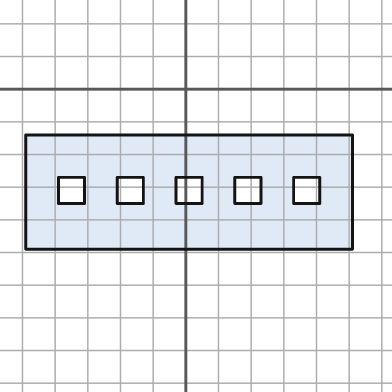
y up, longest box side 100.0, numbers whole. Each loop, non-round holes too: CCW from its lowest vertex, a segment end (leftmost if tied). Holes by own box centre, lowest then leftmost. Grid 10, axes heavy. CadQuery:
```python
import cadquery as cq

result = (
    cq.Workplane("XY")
    .moveTo(-49.0, -49.0)
    .lineTo(51.0, -49.0)
    .lineTo(51.0, -14.0)
    .lineTo(-49.0, -14.0)
    .close()
    .moveTo(-39.0, -35.0)
    .lineTo(-31.0, -35.0)
    .lineTo(-31.0, -27.0)
    .lineTo(-39.0, -27.0)
    .close()
    .moveTo(-21.0, -35.0)
    .lineTo(-13.0, -35.0)
    .lineTo(-13.0, -27.0)
    .lineTo(-21.0, -27.0)
    .close()
    .moveTo(-3.0, -35.0)
    .lineTo(5.0, -35.0)
    .lineTo(5.0, -27.0)
    .lineTo(-3.0, -27.0)
    .close()
    .moveTo(15.0, -35.0)
    .lineTo(23.0, -35.0)
    .lineTo(23.0, -27.0)
    .lineTo(15.0, -27.0)
    .close()
    .moveTo(33.0, -35.0)
    .lineTo(41.0, -35.0)
    .lineTo(41.0, -27.0)
    .lineTo(33.0, -27.0)
    .close()
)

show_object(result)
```